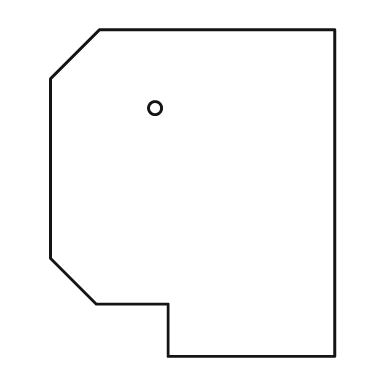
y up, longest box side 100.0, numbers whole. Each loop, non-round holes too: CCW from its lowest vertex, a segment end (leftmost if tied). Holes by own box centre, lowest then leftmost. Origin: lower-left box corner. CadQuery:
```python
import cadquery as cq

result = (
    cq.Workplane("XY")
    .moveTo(36.0, 0.0)
    .lineTo(87.0, 0.0)
    .lineTo(87.0, 100.0)
    .lineTo(15.0, 100.0)
    .lineTo(0.0, 85.0)
    .lineTo(0.0, 30.0)
    .lineTo(14.0, 16.0)
    .lineTo(36.0, 16.0)
    .close()
    .moveTo(32.0, 76.0)
    .circle(2.0)
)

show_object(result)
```